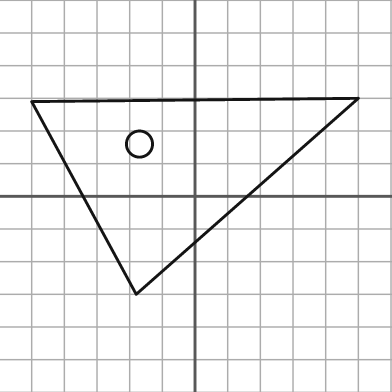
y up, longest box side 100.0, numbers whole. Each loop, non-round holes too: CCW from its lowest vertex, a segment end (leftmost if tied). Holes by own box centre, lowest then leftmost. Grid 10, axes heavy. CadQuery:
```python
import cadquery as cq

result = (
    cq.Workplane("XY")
    .moveTo(-18.0, -30.0)
    .lineTo(50.0, 30.0)
    .lineTo(-50.0, 29.0)
    .close()
    .moveTo(-17.0, 16.0)
    .circle(4.0)
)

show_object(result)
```